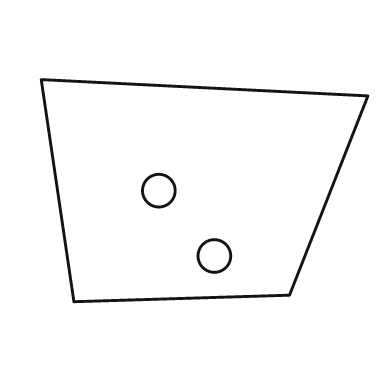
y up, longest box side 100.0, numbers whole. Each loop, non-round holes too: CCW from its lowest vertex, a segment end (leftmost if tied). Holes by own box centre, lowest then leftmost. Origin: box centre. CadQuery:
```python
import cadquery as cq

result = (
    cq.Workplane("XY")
    .moveTo(-40.0, -34.0)
    .lineTo(26.0, -32.0)
    .lineTo(50.0, 29.0)
    .lineTo(-50.0, 34.0)
    .close()
    .moveTo(3.0, -20.0)
    .circle(5.0)
    .moveTo(-14.0, 0.0)
    .circle(5.0)
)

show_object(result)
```